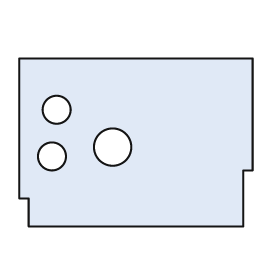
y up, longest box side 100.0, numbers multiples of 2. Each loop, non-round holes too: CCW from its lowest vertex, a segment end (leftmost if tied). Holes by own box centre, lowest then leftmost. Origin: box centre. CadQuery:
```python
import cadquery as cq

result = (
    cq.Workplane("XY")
    .moveTo(-46.0, -36.0)
    .lineTo(46.0, -36.0)
    .lineTo(46.0, -12.0)
    .lineTo(50.0, -12.0)
    .lineTo(50.0, 36.0)
    .lineTo(-50.0, 36.0)
    .lineTo(-50.0, -24.0)
    .lineTo(-46.0, -24.0)
    .close()
    .moveTo(-36.0, -6.0)
    .circle(6.0)
    .moveTo(-10.0, -2.0)
    .circle(8.0)
    .moveTo(-34.0, 14.0)
    .circle(6.0)
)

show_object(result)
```